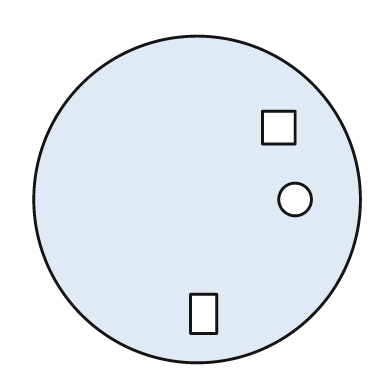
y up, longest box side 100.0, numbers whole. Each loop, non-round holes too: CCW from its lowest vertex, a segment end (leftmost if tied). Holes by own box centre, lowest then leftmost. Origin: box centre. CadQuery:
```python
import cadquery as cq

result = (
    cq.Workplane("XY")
    .moveTo(0.0, 0.0)
    .circle(50.0)
    .moveTo(-2.0, -41.0)
    .lineTo(6.0, -41.0)
    .lineTo(6.0, -29.0)
    .lineTo(-2.0, -29.0)
    .close()
    .moveTo(30.0, 0.0)
    .circle(5.0)
    .moveTo(20.0, 17.0)
    .lineTo(30.0, 17.0)
    .lineTo(30.0, 27.0)
    .lineTo(20.0, 27.0)
    .close()
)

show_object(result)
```